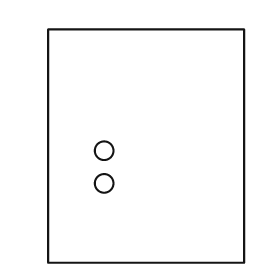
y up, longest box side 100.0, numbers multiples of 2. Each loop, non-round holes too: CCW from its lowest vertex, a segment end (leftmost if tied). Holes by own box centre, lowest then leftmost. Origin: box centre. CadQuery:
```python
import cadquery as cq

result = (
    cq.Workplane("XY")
    .moveTo(-42.0, -50.0)
    .lineTo(42.0, -50.0)
    .lineTo(42.0, 50.0)
    .lineTo(-42.0, 50.0)
    .close()
    .moveTo(-18.0, -16.0)
    .circle(4.0)
    .moveTo(-18.0, -2.0)
    .circle(4.0)
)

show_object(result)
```